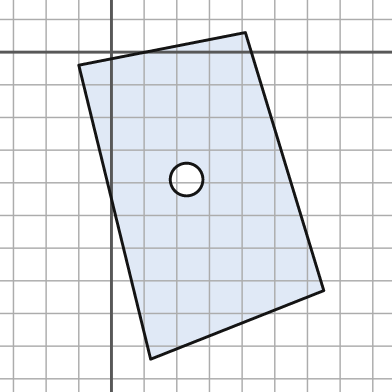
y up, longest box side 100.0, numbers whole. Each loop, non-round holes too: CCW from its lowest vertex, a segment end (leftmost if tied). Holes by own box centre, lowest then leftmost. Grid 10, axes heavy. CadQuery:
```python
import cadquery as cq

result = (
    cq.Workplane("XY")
    .moveTo(12.0, -94.0)
    .lineTo(65.0, -73.0)
    .lineTo(41.0, 6.0)
    .lineTo(-10.0, -4.0)
    .close()
    .moveTo(23.0, -39.0)
    .circle(5.0)
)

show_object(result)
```